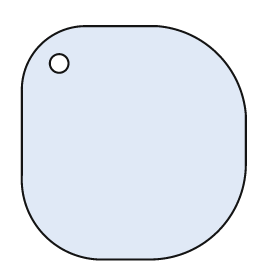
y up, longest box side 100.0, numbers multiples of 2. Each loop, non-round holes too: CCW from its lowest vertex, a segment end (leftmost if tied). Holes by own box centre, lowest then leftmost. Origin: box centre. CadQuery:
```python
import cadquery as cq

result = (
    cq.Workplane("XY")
    .moveTo(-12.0, -50.0)
    .lineTo(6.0, -50.0)
    .threePointArc((36.0, -38.0), (48.0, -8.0))
    .lineTo(48.0, 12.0)
    .threePointArc((36.0, 38.0), (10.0, 50.0))
    .lineTo(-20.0, 50.0)
    .threePointArc((-40.0, 42.0), (-48.0, 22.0))
    .lineTo(-48.0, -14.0)
    .threePointArc((-38.0, -40.0), (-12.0, -50.0))
    .close()
    .moveTo(-32.0, 34.0)
    .circle(4.0)
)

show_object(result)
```